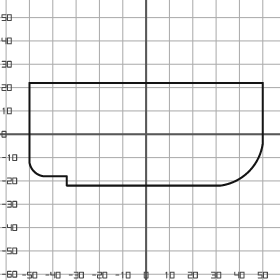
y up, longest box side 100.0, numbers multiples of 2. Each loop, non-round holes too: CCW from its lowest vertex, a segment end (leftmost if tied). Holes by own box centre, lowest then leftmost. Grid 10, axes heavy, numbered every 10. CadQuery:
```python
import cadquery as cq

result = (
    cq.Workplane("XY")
    .moveTo(-34.0, -22.0)
    .lineTo(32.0, -22.0)
    .threePointArc((44.0, -16.0), (50.0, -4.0))
    .lineTo(50.0, 22.0)
    .lineTo(-50.0, 22.0)
    .lineTo(-50.0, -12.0)
    .threePointArc((-48.0, -16.0), (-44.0, -18.0))
    .lineTo(-34.0, -18.0)
    .close()
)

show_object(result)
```